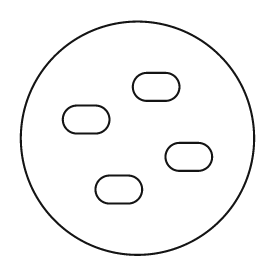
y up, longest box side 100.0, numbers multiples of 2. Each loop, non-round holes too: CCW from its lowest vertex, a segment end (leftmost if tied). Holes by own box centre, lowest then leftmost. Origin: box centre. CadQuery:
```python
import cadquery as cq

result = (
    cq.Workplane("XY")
    .moveTo(0.0, 0.0)
    .circle(50.0)
    .moveTo(-12.0, -28.0)
    .lineTo(-4.0, -28.0)
    .threePointArc((2.0, -22.0), (-4.0, -16.0))
    .lineTo(-12.0, -16.0)
    .threePointArc((-18.0, -22.0), (-12.0, -28.0))
    .close()
    .moveTo(18.0, -14.0)
    .lineTo(26.0, -14.0)
    .threePointArc((32.0, -8.0), (26.0, -2.0))
    .lineTo(18.0, -2.0)
    .threePointArc((12.0, -8.0), (18.0, -14.0))
    .close()
    .moveTo(-26.0, 2.0)
    .lineTo(-18.0, 2.0)
    .threePointArc((-12.0, 8.0), (-18.0, 14.0))
    .lineTo(-26.0, 14.0)
    .threePointArc((-32.0, 8.0), (-26.0, 2.0))
    .close()
    .moveTo(4.0, 16.0)
    .lineTo(12.0, 16.0)
    .threePointArc((18.0, 22.0), (12.0, 28.0))
    .lineTo(4.0, 28.0)
    .threePointArc((-2.0, 22.0), (4.0, 16.0))
    .close()
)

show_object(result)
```